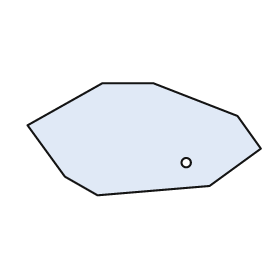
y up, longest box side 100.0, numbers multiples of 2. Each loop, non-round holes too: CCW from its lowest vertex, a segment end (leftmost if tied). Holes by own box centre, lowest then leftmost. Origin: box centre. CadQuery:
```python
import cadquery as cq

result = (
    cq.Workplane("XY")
    .moveTo(-20.0, -24.0)
    .lineTo(28.0, -20.0)
    .lineTo(50.0, -4.0)
    .lineTo(40.0, 10.0)
    .lineTo(4.0, 24.0)
    .lineTo(-18.0, 24.0)
    .lineTo(-50.0, 6.0)
    .lineTo(-34.0, -16.0)
    .close()
    .moveTo(18.0, -10.0)
    .circle(2.0)
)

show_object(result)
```